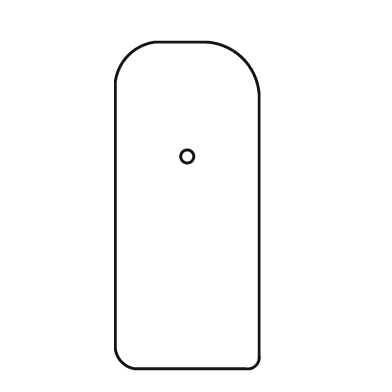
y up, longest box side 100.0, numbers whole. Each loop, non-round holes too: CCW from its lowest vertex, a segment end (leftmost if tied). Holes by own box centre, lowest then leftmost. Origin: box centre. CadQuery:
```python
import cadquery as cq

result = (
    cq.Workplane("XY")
    .moveTo(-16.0, -50.0)
    .lineTo(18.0, -50.0)
    .threePointArc((21.0, -49.0), (22.0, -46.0))
    .lineTo(22.0, 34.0)
    .threePointArc((17.0, 45.0), (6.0, 50.0))
    .lineTo(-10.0, 50.0)
    .threePointArc((-18.0, 46.0), (-22.0, 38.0))
    .lineTo(-22.0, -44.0)
    .threePointArc((-20.0, -48.0), (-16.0, -50.0))
    .close()
    .moveTo(0.0, 15.0)
    .circle(2.0)
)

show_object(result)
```